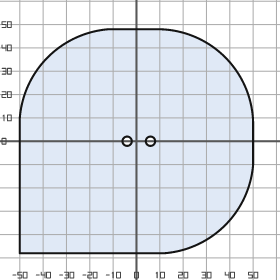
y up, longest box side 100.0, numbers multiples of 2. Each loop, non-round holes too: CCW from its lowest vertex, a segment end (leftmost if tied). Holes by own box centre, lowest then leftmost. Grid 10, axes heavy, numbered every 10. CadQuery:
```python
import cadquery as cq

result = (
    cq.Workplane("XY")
    .moveTo(-50.0, -48.0)
    .lineTo(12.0, -48.0)
    .threePointArc((38.0, -36.0), (50.0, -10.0))
    .lineTo(50.0, 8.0)
    .threePointArc((38.0, 36.0), (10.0, 48.0))
    .lineTo(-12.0, 48.0)
    .threePointArc((-38.0, 36.0), (-50.0, 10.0))
    .close()
    .moveTo(-4.0, 0.0)
    .circle(2.0)
    .moveTo(6.0, 0.0)
    .circle(2.0)
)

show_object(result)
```